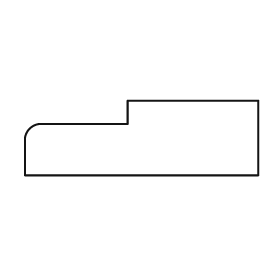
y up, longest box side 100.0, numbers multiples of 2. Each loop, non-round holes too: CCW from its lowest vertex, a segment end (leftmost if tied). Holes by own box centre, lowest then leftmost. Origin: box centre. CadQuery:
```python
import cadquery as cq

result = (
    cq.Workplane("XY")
    .moveTo(-50.0, -16.0)
    .lineTo(50.0, -16.0)
    .lineTo(50.0, 16.0)
    .lineTo(-6.0, 16.0)
    .lineTo(-6.0, 6.0)
    .lineTo(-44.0, 6.0)
    .threePointArc((-48.0, 4.0), (-50.0, 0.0))
    .close()
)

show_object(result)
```